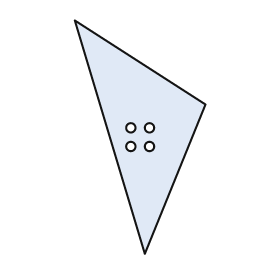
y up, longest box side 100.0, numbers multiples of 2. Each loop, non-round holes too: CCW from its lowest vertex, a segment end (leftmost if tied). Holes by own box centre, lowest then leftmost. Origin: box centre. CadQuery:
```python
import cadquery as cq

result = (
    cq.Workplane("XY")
    .moveTo(2.0, -50.0)
    .lineTo(28.0, 14.0)
    .lineTo(-28.0, 50.0)
    .close()
    .moveTo(-4.0, -4.0)
    .circle(2.0)
    .moveTo(4.0, -4.0)
    .circle(2.0)
    .moveTo(-4.0, 4.0)
    .circle(2.0)
    .moveTo(4.0, 4.0)
    .circle(2.0)
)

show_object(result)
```